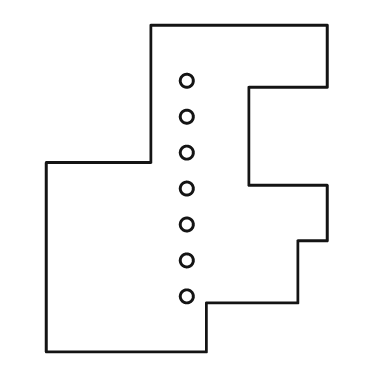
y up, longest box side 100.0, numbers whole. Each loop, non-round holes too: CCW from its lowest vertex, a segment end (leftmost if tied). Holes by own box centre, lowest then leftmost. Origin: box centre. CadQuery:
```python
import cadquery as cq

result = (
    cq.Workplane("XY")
    .moveTo(-43.0, -50.0)
    .lineTo(6.0, -50.0)
    .lineTo(6.0, -35.0)
    .lineTo(34.0, -35.0)
    .lineTo(34.0, -16.0)
    .lineTo(43.0, -16.0)
    .lineTo(43.0, 1.0)
    .lineTo(19.0, 1.0)
    .lineTo(19.0, 31.0)
    .lineTo(43.0, 31.0)
    .lineTo(43.0, 50.0)
    .lineTo(-11.0, 50.0)
    .lineTo(-11.0, 8.0)
    .lineTo(-43.0, 8.0)
    .close()
    .moveTo(0.0, -33.0)
    .circle(2.0)
    .moveTo(0.0, -22.0)
    .circle(2.0)
    .moveTo(0.0, -11.0)
    .circle(2.0)
    .moveTo(0.0, 0.0)
    .circle(2.0)
    .moveTo(0.0, 11.0)
    .circle(2.0)
    .moveTo(0.0, 22.0)
    .circle(2.0)
    .moveTo(0.0, 33.0)
    .circle(2.0)
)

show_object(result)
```